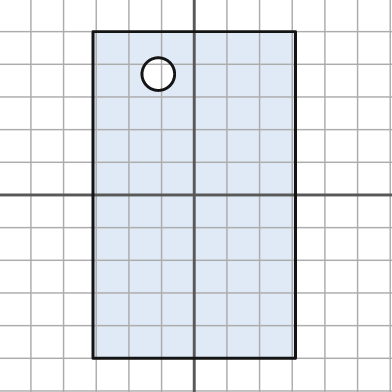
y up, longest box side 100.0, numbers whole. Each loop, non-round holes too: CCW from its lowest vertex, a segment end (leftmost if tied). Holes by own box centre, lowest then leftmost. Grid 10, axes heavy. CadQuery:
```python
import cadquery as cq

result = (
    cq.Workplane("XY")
    .moveTo(-31.0, -50.0)
    .lineTo(31.0, -50.0)
    .lineTo(31.0, 50.0)
    .lineTo(-31.0, 50.0)
    .close()
    .moveTo(-11.0, 37.0)
    .circle(5.0)
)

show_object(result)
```